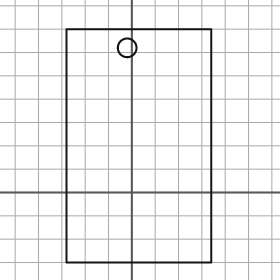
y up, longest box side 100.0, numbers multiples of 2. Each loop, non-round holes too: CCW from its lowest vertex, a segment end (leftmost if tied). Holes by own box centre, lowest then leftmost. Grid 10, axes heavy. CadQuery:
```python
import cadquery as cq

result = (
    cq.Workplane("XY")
    .moveTo(-28.0, -30.0)
    .lineTo(34.0, -30.0)
    .lineTo(34.0, 70.0)
    .lineTo(-28.0, 70.0)
    .close()
    .moveTo(-2.0, 62.0)
    .circle(4.0)
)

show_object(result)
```